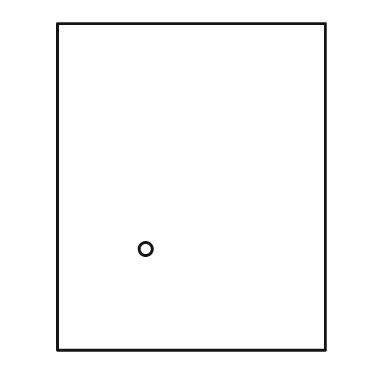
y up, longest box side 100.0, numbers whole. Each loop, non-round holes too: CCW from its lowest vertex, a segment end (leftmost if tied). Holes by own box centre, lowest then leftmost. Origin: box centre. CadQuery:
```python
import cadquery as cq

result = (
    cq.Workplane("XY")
    .moveTo(-41.0, -50.0)
    .lineTo(41.0, -50.0)
    .lineTo(41.0, 50.0)
    .lineTo(-41.0, 50.0)
    .close()
    .moveTo(-14.0, -19.0)
    .circle(2.0)
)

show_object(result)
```